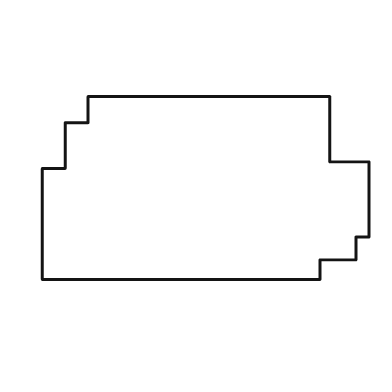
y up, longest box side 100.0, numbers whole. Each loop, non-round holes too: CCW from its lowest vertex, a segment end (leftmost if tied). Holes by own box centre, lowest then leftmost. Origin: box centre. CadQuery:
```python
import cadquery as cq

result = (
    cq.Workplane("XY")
    .moveTo(-50.0, -28.0)
    .lineTo(35.0, -28.0)
    .lineTo(35.0, -22.0)
    .lineTo(46.0, -22.0)
    .lineTo(46.0, -15.0)
    .lineTo(50.0, -15.0)
    .lineTo(50.0, 8.0)
    .lineTo(38.0, 8.0)
    .lineTo(38.0, 28.0)
    .lineTo(-36.0, 28.0)
    .lineTo(-36.0, 20.0)
    .lineTo(-43.0, 20.0)
    .lineTo(-43.0, 6.0)
    .lineTo(-50.0, 6.0)
    .close()
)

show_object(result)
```